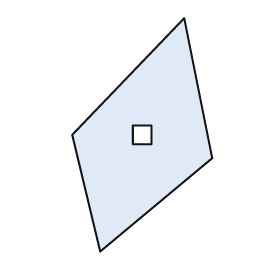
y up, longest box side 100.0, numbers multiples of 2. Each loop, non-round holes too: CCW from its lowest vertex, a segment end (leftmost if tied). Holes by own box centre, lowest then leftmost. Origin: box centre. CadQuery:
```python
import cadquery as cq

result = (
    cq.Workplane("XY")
    .moveTo(-18.0, -50.0)
    .lineTo(30.0, -10.0)
    .lineTo(18.0, 50.0)
    .lineTo(-30.0, 0.0)
    .close()
    .moveTo(-4.0, -4.0)
    .lineTo(4.0, -4.0)
    .lineTo(4.0, 4.0)
    .lineTo(-4.0, 4.0)
    .close()
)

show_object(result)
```